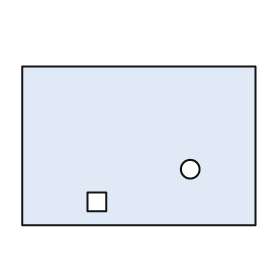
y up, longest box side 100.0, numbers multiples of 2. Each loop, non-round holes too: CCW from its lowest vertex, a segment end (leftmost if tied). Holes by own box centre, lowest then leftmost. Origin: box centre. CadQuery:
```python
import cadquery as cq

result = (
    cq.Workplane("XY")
    .moveTo(-50.0, -34.0)
    .lineTo(50.0, -34.0)
    .lineTo(50.0, 34.0)
    .lineTo(-50.0, 34.0)
    .close()
    .moveTo(-22.0, -28.0)
    .lineTo(-14.0, -28.0)
    .lineTo(-14.0, -20.0)
    .lineTo(-22.0, -20.0)
    .close()
    .moveTo(22.0, -10.0)
    .circle(4.0)
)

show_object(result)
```